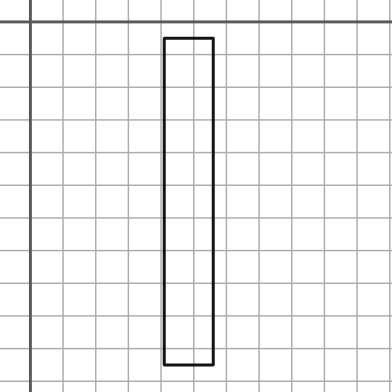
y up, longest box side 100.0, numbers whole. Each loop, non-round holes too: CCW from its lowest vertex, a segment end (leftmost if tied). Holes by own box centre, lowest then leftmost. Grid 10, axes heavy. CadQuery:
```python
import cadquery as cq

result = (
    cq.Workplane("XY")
    .moveTo(41.0, -105.0)
    .lineTo(56.0, -105.0)
    .lineTo(56.0, -5.0)
    .lineTo(41.0, -5.0)
    .close()
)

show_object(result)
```